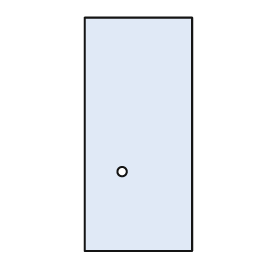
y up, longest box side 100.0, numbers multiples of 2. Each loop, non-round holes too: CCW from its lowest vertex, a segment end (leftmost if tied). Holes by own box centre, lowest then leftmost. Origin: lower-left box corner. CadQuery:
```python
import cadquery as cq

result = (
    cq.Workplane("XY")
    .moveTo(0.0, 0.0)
    .lineTo(46.0, 0.0)
    .lineTo(46.0, 100.0)
    .lineTo(0.0, 100.0)
    .close()
    .moveTo(16.0, 34.0)
    .circle(2.0)
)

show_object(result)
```